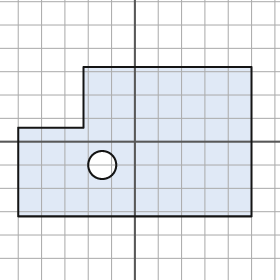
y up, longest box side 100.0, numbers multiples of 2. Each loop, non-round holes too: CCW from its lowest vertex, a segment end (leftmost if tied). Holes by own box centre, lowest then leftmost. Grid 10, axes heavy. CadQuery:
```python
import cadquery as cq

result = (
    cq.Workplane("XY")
    .moveTo(-50.0, -32.0)
    .lineTo(50.0, -32.0)
    .lineTo(50.0, 32.0)
    .lineTo(-22.0, 32.0)
    .lineTo(-22.0, 6.0)
    .lineTo(-50.0, 6.0)
    .close()
    .moveTo(-14.0, -10.0)
    .circle(6.0)
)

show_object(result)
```